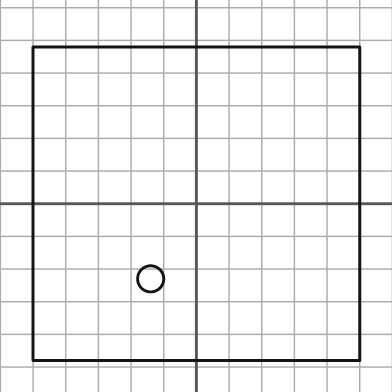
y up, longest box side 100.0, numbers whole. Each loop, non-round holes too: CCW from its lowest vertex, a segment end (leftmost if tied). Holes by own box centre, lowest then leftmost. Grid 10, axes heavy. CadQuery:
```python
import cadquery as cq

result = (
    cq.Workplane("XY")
    .moveTo(-50.0, -48.0)
    .lineTo(50.0, -48.0)
    .lineTo(50.0, 48.0)
    .lineTo(-50.0, 48.0)
    .close()
    .moveTo(-14.0, -23.0)
    .circle(4.0)
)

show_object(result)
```